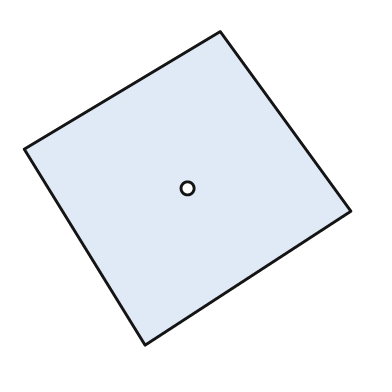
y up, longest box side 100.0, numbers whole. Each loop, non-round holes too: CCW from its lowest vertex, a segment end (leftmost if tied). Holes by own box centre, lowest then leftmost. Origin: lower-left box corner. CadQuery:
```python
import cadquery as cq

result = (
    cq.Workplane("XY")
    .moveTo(37.0, 0.0)
    .lineTo(100.0, 41.0)
    .lineTo(60.0, 96.0)
    .lineTo(0.0, 60.0)
    .close()
    .moveTo(50.0, 48.0)
    .circle(2.0)
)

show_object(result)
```